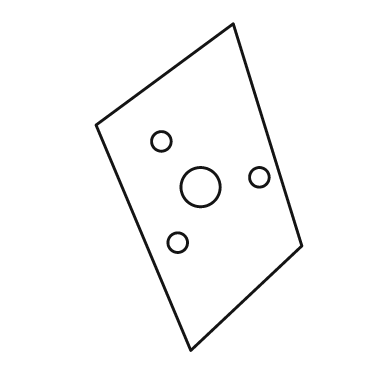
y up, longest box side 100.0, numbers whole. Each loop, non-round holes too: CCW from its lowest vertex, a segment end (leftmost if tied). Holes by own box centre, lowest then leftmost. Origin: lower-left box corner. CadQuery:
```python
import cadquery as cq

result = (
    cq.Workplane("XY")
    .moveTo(29.0, 0.0)
    .lineTo(63.0, 32.0)
    .lineTo(42.0, 100.0)
    .lineTo(0.0, 69.0)
    .close()
    .moveTo(25.0, 33.0)
    .circle(3.0)
    .moveTo(32.0, 50.0)
    .circle(6.0)
    .moveTo(50.0, 53.0)
    .circle(3.0)
    .moveTo(20.0, 64.0)
    .circle(3.0)
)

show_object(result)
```